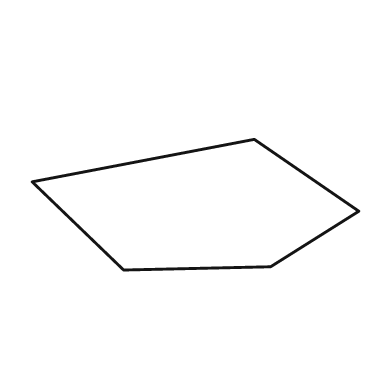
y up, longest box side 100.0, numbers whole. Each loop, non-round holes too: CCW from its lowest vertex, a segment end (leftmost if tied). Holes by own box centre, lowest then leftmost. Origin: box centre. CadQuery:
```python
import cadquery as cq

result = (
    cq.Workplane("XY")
    .moveTo(-22.0, -20.0)
    .lineTo(23.0, -19.0)
    .lineTo(50.0, -2.0)
    .lineTo(18.0, 20.0)
    .lineTo(-50.0, 7.0)
    .close()
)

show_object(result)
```